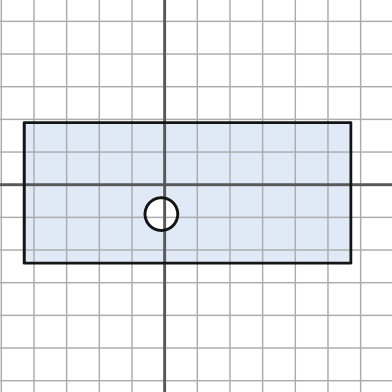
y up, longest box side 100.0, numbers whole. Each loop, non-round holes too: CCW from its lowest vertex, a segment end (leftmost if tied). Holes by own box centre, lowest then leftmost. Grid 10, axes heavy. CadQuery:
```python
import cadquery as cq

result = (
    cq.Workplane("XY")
    .moveTo(-43.0, -24.0)
    .lineTo(57.0, -24.0)
    .lineTo(57.0, 19.0)
    .lineTo(-43.0, 19.0)
    .close()
    .moveTo(-1.0, -9.0)
    .circle(5.0)
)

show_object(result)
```